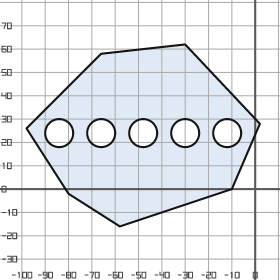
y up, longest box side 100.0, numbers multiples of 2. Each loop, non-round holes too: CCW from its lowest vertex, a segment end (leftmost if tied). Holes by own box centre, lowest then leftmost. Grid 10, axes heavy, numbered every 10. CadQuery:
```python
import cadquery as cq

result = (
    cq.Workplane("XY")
    .moveTo(-58.0, -16.0)
    .lineTo(-10.0, 0.0)
    .lineTo(2.0, 28.0)
    .lineTo(-30.0, 62.0)
    .lineTo(-66.0, 58.0)
    .lineTo(-98.0, 26.0)
    .lineTo(-80.0, -2.0)
    .close()
    .moveTo(-84.0, 24.0)
    .circle(6.0)
    .moveTo(-66.0, 24.0)
    .circle(6.0)
    .moveTo(-48.0, 24.0)
    .circle(6.0)
    .moveTo(-30.0, 24.0)
    .circle(6.0)
    .moveTo(-12.0, 24.0)
    .circle(6.0)
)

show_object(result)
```